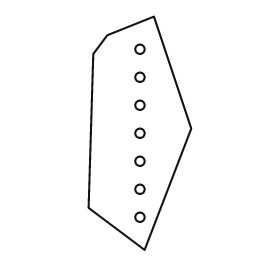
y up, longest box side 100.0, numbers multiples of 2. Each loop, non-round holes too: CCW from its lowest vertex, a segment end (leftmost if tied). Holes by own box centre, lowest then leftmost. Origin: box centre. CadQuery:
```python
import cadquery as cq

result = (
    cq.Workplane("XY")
    .moveTo(2.0, -50.0)
    .lineTo(22.0, 2.0)
    .lineTo(6.0, 50.0)
    .lineTo(-14.0, 42.0)
    .lineTo(-20.0, 34.0)
    .lineTo(-22.0, -32.0)
    .close()
    .moveTo(0.0, -36.0)
    .circle(2.0)
    .moveTo(0.0, -24.0)
    .circle(2.0)
    .moveTo(0.0, -12.0)
    .circle(2.0)
    .moveTo(0.0, 0.0)
    .circle(2.0)
    .moveTo(0.0, 12.0)
    .circle(2.0)
    .moveTo(0.0, 24.0)
    .circle(2.0)
    .moveTo(0.0, 36.0)
    .circle(2.0)
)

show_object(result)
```